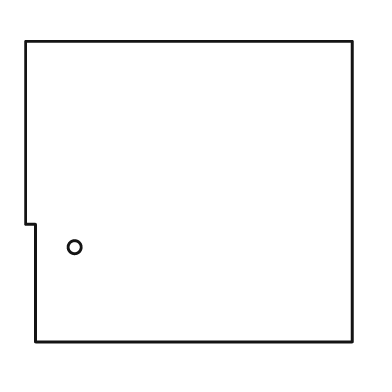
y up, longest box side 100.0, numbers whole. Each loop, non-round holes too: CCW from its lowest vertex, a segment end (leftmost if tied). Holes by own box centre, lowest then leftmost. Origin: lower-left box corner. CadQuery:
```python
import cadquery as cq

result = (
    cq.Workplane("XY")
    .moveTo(3.0, 0.0)
    .lineTo(100.0, 0.0)
    .lineTo(100.0, 92.0)
    .lineTo(0.0, 92.0)
    .lineTo(0.0, 36.0)
    .lineTo(3.0, 36.0)
    .close()
    .moveTo(15.0, 29.0)
    .circle(2.0)
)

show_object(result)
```